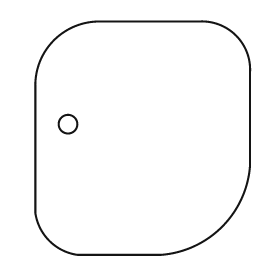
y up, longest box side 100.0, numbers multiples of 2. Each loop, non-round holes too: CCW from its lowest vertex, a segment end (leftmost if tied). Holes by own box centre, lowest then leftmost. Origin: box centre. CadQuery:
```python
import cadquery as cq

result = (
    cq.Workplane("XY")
    .moveTo(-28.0, -50.0)
    .lineTo(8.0, -50.0)
    .threePointArc((34.0, -38.0), (46.0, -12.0))
    .lineTo(46.0, 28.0)
    .threePointArc((40.0, 44.0), (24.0, 50.0))
    .lineTo(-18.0, 50.0)
    .threePointArc((-38.0, 42.0), (-46.0, 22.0))
    .lineTo(-46.0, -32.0)
    .threePointArc((-40.0, -44.0), (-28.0, -50.0))
    .close()
    .moveTo(-32.0, 6.0)
    .circle(4.0)
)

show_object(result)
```